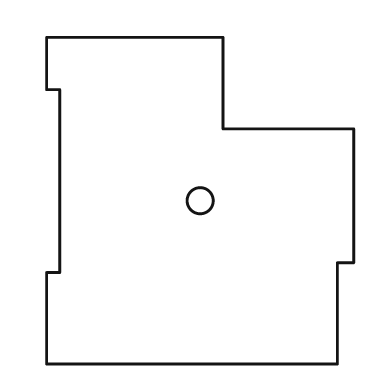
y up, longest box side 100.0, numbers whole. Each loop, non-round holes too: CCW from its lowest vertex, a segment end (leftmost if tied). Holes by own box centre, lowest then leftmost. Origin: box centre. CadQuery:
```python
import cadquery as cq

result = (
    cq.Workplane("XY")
    .moveTo(-47.0, -50.0)
    .lineTo(42.0, -50.0)
    .lineTo(42.0, -19.0)
    .lineTo(47.0, -19.0)
    .lineTo(47.0, 22.0)
    .lineTo(7.0, 22.0)
    .lineTo(7.0, 50.0)
    .lineTo(-47.0, 50.0)
    .lineTo(-47.0, 34.0)
    .lineTo(-43.0, 34.0)
    .lineTo(-43.0, -22.0)
    .lineTo(-47.0, -22.0)
    .close()
    .moveTo(0.0, 0.0)
    .circle(4.0)
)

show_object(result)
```